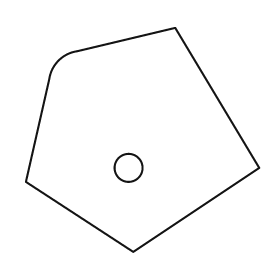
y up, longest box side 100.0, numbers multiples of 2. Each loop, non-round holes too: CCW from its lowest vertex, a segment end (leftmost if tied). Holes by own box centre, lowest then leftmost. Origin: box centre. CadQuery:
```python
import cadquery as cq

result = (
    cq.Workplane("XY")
    .moveTo(-4.0, -48.0)
    .lineTo(50.0, -12.0)
    .lineTo(14.0, 48.0)
    .lineTo(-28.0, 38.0)
    .threePointArc((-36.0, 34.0), (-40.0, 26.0))
    .lineTo(-50.0, -18.0)
    .close()
    .moveTo(-6.0, -12.0)
    .circle(6.0)
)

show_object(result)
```